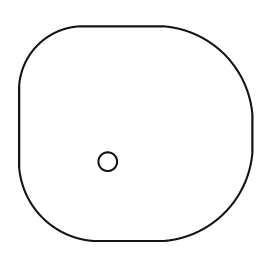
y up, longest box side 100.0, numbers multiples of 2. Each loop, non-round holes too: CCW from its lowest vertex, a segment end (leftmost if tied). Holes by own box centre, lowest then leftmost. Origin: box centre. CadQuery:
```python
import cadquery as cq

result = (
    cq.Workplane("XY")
    .moveTo(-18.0, -46.0)
    .lineTo(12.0, -46.0)
    .threePointArc((38.0, -34.0), (50.0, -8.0))
    .lineTo(50.0, 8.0)
    .threePointArc((38.0, 34.0), (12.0, 46.0))
    .lineTo(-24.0, 46.0)
    .threePointArc((-42.0, 38.0), (-50.0, 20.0))
    .lineTo(-50.0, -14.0)
    .threePointArc((-40.0, -36.0), (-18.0, -46.0))
    .close()
    .moveTo(-12.0, -12.0)
    .circle(4.0)
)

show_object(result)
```